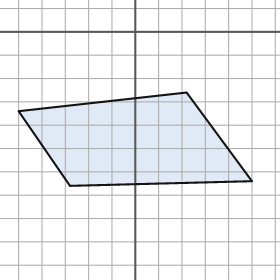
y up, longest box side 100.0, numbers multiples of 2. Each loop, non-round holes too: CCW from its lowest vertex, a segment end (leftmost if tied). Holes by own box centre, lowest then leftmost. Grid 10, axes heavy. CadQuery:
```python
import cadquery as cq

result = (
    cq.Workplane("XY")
    .moveTo(-28.0, -66.0)
    .lineTo(50.0, -64.0)
    .lineTo(22.0, -26.0)
    .lineTo(-50.0, -34.0)
    .close()
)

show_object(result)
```